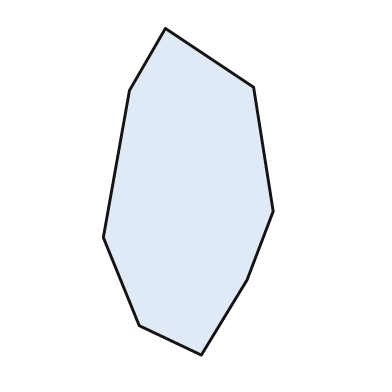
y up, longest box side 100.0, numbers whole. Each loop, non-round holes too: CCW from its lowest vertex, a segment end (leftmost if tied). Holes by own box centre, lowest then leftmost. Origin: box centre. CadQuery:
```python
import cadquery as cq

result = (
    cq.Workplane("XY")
    .moveTo(4.0, -50.0)
    .lineTo(18.0, -27.0)
    .lineTo(26.0, -6.0)
    .lineTo(20.0, 32.0)
    .lineTo(-7.0, 50.0)
    .lineTo(-18.0, 31.0)
    .lineTo(-26.0, -14.0)
    .lineTo(-15.0, -41.0)
    .close()
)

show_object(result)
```